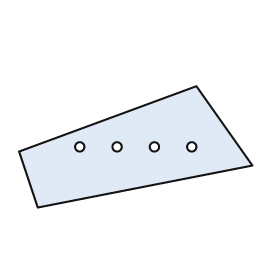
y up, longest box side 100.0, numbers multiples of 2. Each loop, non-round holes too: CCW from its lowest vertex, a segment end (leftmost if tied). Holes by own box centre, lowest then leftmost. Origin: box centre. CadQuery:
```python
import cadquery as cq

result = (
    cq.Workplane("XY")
    .moveTo(-42.0, -26.0)
    .lineTo(50.0, -8.0)
    .lineTo(26.0, 26.0)
    .lineTo(-50.0, -2.0)
    .close()
    .moveTo(-24.0, 0.0)
    .circle(2.0)
    .moveTo(-8.0, 0.0)
    .circle(2.0)
    .moveTo(8.0, 0.0)
    .circle(2.0)
    .moveTo(24.0, 0.0)
    .circle(2.0)
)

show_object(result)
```